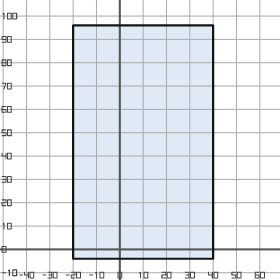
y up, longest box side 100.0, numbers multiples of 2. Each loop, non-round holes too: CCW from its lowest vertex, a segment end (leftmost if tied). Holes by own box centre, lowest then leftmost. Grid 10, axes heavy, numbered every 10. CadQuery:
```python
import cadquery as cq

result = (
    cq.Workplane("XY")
    .moveTo(-20.0, -4.0)
    .lineTo(40.0, -4.0)
    .lineTo(40.0, 96.0)
    .lineTo(-20.0, 96.0)
    .close()
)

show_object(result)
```